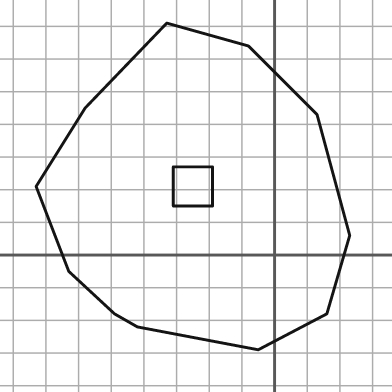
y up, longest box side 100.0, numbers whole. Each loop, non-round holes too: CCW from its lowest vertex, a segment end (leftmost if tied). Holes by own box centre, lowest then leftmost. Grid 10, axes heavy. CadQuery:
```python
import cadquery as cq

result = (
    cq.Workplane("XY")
    .moveTo(-5.0, -29.0)
    .lineTo(16.0, -18.0)
    .lineTo(23.0, 6.0)
    .lineTo(13.0, 43.0)
    .lineTo(-8.0, 64.0)
    .lineTo(-33.0, 71.0)
    .lineTo(-58.0, 45.0)
    .lineTo(-73.0, 21.0)
    .lineTo(-63.0, -5.0)
    .lineTo(-49.0, -18.0)
    .lineTo(-42.0, -22.0)
    .close()
    .moveTo(-31.0, 15.0)
    .lineTo(-19.0, 15.0)
    .lineTo(-19.0, 27.0)
    .lineTo(-31.0, 27.0)
    .close()
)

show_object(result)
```